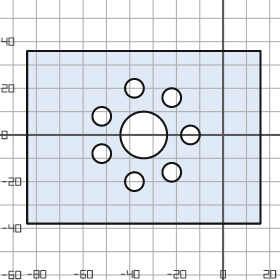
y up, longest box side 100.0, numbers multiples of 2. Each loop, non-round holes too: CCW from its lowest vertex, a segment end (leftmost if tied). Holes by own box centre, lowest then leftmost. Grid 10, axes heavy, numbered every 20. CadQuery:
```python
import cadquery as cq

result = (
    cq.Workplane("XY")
    .moveTo(-84.0, -38.0)
    .lineTo(16.0, -38.0)
    .lineTo(16.0, 36.0)
    .lineTo(-84.0, 36.0)
    .close()
    .moveTo(-38.0, -20.0)
    .circle(4.0)
    .moveTo(-22.0, -16.0)
    .circle(4.0)
    .moveTo(-52.0, -8.0)
    .circle(4.0)
    .moveTo(-34.0, 0.0)
    .circle(10.0)
    .moveTo(-14.0, 0.0)
    .circle(4.0)
    .moveTo(-52.0, 8.0)
    .circle(4.0)
    .moveTo(-22.0, 16.0)
    .circle(4.0)
    .moveTo(-38.0, 20.0)
    .circle(4.0)
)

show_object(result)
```